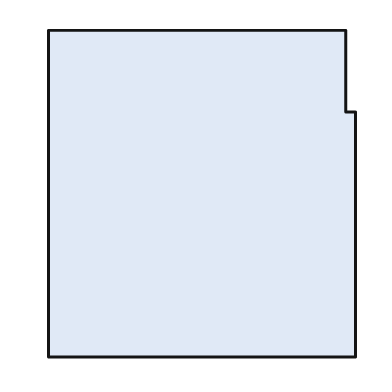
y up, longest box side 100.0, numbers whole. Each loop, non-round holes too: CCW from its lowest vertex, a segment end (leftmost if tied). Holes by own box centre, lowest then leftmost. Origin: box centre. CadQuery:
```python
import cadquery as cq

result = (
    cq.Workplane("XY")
    .moveTo(-47.0, -50.0)
    .lineTo(47.0, -50.0)
    .lineTo(47.0, 25.0)
    .lineTo(44.0, 25.0)
    .lineTo(44.0, 50.0)
    .lineTo(-47.0, 50.0)
    .close()
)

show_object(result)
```